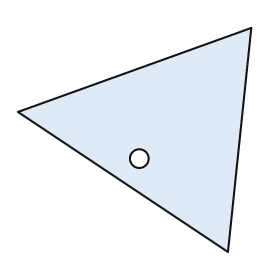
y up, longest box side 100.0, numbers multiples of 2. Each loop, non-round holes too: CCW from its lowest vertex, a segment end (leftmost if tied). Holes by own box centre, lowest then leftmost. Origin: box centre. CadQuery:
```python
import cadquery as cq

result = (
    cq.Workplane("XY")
    .moveTo(40.0, -48.0)
    .lineTo(50.0, 48.0)
    .lineTo(-50.0, 12.0)
    .close()
    .moveTo(2.0, -8.0)
    .circle(4.0)
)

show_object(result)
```